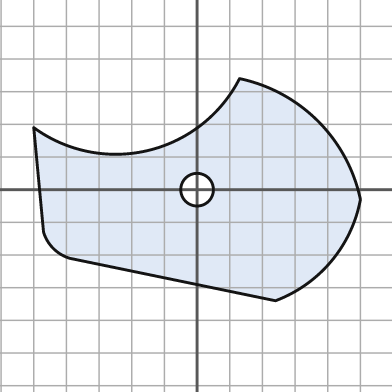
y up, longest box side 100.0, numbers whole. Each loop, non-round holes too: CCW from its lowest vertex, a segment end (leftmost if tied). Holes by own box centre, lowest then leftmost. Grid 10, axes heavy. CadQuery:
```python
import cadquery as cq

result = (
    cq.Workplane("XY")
    .moveTo(24.0, -34.0)
    .threePointArc((41.0, -22.0), (50.0, -3.0))
    .threePointArc((37.0, 21.0), (13.0, 34.0))
    .threePointArc((-15.0, 12.0), (-50.0, 19.0))
    .lineTo(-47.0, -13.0)
    .threePointArc((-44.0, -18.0), (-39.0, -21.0))
    .close()
    .moveTo(0.0, 0.0)
    .circle(5.0)
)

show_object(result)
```